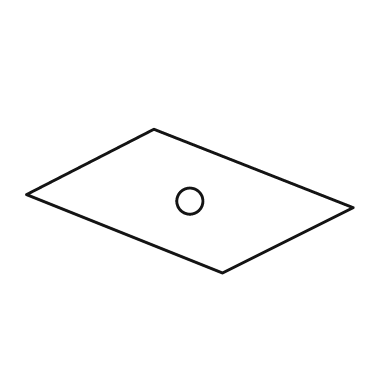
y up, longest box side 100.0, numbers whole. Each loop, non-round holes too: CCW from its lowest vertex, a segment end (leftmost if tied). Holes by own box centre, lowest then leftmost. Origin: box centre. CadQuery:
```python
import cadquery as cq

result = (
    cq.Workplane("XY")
    .moveTo(10.0, -22.0)
    .lineTo(50.0, -2.0)
    .lineTo(-11.0, 22.0)
    .lineTo(-50.0, 2.0)
    .close()
    .moveTo(0.0, 0.0)
    .circle(4.0)
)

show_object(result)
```